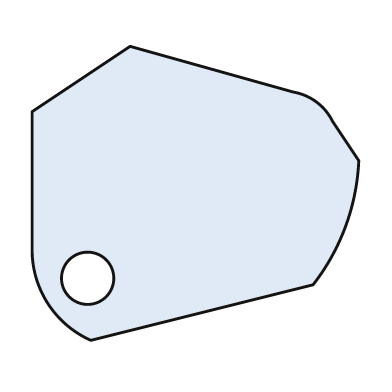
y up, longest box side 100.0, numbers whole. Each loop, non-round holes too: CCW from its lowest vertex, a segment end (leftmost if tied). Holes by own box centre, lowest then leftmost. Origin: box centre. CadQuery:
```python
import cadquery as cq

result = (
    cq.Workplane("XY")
    .moveTo(-32.0, -45.0)
    .lineTo(36.0, -28.0)
    .threePointArc((46.0, -10.0), (50.0, 10.0))
    .lineTo(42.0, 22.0)
    .threePointArc((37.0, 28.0), (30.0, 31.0))
    .lineTo(-20.0, 45.0)
    .lineTo(-50.0, 25.0)
    .lineTo(-50.0, -18.0)
    .threePointArc((-45.0, -34.0), (-32.0, -45.0))
    .close()
    .moveTo(-33.0, -26.0)
    .circle(8.0)
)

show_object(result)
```